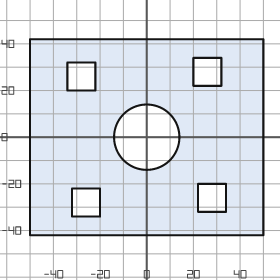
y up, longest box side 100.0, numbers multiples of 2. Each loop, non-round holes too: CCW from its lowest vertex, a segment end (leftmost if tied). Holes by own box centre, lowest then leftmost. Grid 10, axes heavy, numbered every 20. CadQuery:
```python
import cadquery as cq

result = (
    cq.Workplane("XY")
    .moveTo(-50.0, -42.0)
    .lineTo(50.0, -42.0)
    .lineTo(50.0, 42.0)
    .lineTo(-50.0, 42.0)
    .close()
    .moveTo(-32.0, -34.0)
    .lineTo(-20.0, -34.0)
    .lineTo(-20.0, -22.0)
    .lineTo(-32.0, -22.0)
    .close()
    .moveTo(22.0, -32.0)
    .lineTo(34.0, -32.0)
    .lineTo(34.0, -20.0)
    .lineTo(22.0, -20.0)
    .close()
    .moveTo(0.0, 0.0)
    .circle(14.0)
    .moveTo(-34.0, 20.0)
    .lineTo(-22.0, 20.0)
    .lineTo(-22.0, 32.0)
    .lineTo(-34.0, 32.0)
    .close()
    .moveTo(20.0, 22.0)
    .lineTo(32.0, 22.0)
    .lineTo(32.0, 34.0)
    .lineTo(20.0, 34.0)
    .close()
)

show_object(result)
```